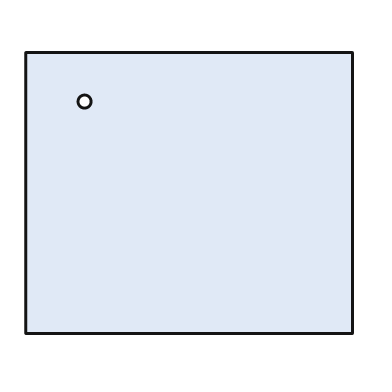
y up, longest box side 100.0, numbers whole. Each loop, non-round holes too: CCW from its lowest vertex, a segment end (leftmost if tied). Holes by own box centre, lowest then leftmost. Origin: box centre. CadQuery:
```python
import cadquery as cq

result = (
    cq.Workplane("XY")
    .moveTo(-50.0, -43.0)
    .lineTo(50.0, -43.0)
    .lineTo(50.0, 43.0)
    .lineTo(-50.0, 43.0)
    .close()
    .moveTo(-32.0, 28.0)
    .circle(2.0)
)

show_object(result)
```